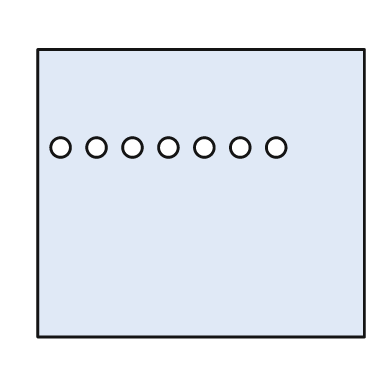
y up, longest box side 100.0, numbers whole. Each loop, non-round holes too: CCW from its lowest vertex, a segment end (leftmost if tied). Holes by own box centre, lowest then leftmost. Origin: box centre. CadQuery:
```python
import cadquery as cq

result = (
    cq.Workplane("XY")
    .moveTo(-50.0, -44.0)
    .lineTo(50.0, -44.0)
    .lineTo(50.0, 44.0)
    .lineTo(-50.0, 44.0)
    .close()
    .moveTo(-43.0, 14.0)
    .circle(3.0)
    .moveTo(-32.0, 14.0)
    .circle(3.0)
    .moveTo(-21.0, 14.0)
    .circle(3.0)
    .moveTo(-10.0, 14.0)
    .circle(3.0)
    .moveTo(1.0, 14.0)
    .circle(3.0)
    .moveTo(12.0, 14.0)
    .circle(3.0)
    .moveTo(23.0, 14.0)
    .circle(3.0)
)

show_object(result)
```